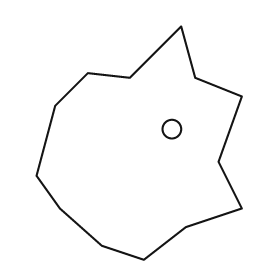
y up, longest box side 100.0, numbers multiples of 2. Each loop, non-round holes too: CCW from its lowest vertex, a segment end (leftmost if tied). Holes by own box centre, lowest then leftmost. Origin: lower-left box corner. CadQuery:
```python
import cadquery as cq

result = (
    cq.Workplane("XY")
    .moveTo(46.0, 0.0)
    .lineTo(64.0, 14.0)
    .lineTo(88.0, 22.0)
    .lineTo(78.0, 42.0)
    .lineTo(88.0, 70.0)
    .lineTo(68.0, 78.0)
    .lineTo(62.0, 100.0)
    .lineTo(40.0, 78.0)
    .lineTo(22.0, 80.0)
    .lineTo(8.0, 66.0)
    .lineTo(0.0, 36.0)
    .lineTo(10.0, 22.0)
    .lineTo(28.0, 6.0)
    .close()
    .moveTo(58.0, 56.0)
    .circle(4.0)
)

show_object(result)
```